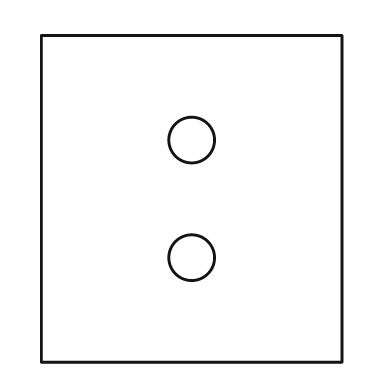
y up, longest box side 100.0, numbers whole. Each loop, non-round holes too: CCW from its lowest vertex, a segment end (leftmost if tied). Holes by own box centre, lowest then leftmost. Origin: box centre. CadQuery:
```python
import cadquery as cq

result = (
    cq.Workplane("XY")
    .moveTo(-46.0, -50.0)
    .lineTo(46.0, -50.0)
    .lineTo(46.0, 50.0)
    .lineTo(-46.0, 50.0)
    .close()
    .moveTo(0.0, -18.0)
    .circle(7.0)
    .moveTo(0.0, 18.0)
    .circle(7.0)
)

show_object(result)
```